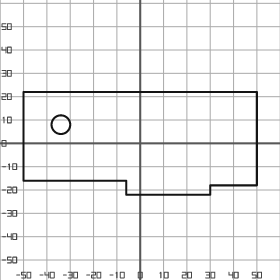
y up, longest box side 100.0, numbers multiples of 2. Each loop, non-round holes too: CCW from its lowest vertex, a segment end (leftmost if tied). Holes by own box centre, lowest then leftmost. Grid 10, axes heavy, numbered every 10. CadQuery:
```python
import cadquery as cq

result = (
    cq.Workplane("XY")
    .moveTo(-6.0, -22.0)
    .lineTo(30.0, -22.0)
    .lineTo(30.0, -18.0)
    .lineTo(50.0, -18.0)
    .lineTo(50.0, 22.0)
    .lineTo(-50.0, 22.0)
    .lineTo(-50.0, -16.0)
    .lineTo(-6.0, -16.0)
    .close()
    .moveTo(-34.0, 8.0)
    .circle(4.0)
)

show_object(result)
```